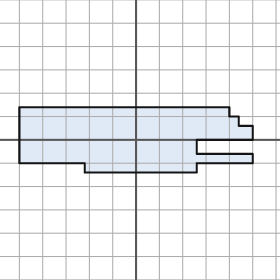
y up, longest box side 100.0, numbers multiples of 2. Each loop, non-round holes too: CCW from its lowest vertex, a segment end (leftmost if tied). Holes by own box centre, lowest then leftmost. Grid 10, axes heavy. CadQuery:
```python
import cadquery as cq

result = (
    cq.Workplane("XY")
    .moveTo(-22.0, -14.0)
    .lineTo(26.0, -14.0)
    .lineTo(26.0, -10.0)
    .lineTo(50.0, -10.0)
    .lineTo(50.0, -6.0)
    .lineTo(26.0, -6.0)
    .lineTo(26.0, 0.0)
    .lineTo(50.0, 0.0)
    .lineTo(50.0, 6.0)
    .lineTo(44.0, 6.0)
    .lineTo(44.0, 10.0)
    .lineTo(40.0, 10.0)
    .lineTo(40.0, 14.0)
    .lineTo(-50.0, 14.0)
    .lineTo(-50.0, -10.0)
    .lineTo(-22.0, -10.0)
    .close()
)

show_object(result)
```